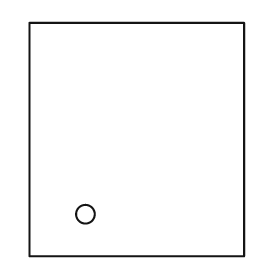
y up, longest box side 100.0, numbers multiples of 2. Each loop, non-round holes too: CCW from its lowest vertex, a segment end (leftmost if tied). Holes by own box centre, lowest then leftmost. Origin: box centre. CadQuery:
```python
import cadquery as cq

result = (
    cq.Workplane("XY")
    .moveTo(-46.0, -50.0)
    .lineTo(46.0, -50.0)
    .lineTo(46.0, 50.0)
    .lineTo(-46.0, 50.0)
    .close()
    .moveTo(-22.0, -32.0)
    .circle(4.0)
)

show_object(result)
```